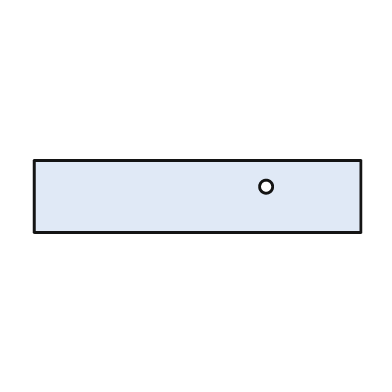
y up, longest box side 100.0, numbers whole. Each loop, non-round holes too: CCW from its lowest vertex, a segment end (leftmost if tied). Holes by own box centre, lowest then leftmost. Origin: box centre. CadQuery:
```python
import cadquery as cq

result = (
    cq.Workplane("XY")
    .moveTo(-50.0, -11.0)
    .lineTo(50.0, -11.0)
    .lineTo(50.0, 11.0)
    .lineTo(-50.0, 11.0)
    .close()
    .moveTo(21.0, 3.0)
    .circle(2.0)
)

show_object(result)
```